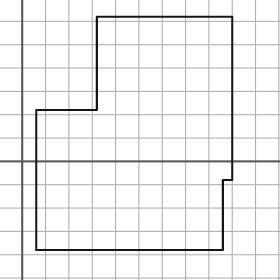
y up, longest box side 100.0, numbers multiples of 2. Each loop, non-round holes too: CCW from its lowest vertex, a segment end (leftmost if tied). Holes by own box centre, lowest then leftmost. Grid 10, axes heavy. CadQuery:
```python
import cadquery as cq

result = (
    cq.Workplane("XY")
    .moveTo(6.0, -38.0)
    .lineTo(86.0, -38.0)
    .lineTo(86.0, -8.0)
    .lineTo(90.0, -8.0)
    .lineTo(90.0, 62.0)
    .lineTo(32.0, 62.0)
    .lineTo(32.0, 22.0)
    .lineTo(6.0, 22.0)
    .close()
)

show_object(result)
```